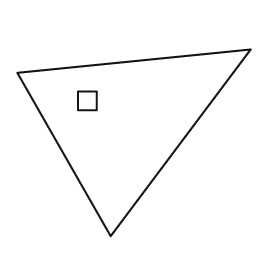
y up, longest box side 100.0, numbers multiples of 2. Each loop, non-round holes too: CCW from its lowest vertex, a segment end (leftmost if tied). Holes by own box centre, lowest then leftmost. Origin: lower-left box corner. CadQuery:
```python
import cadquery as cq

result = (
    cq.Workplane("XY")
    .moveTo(40.0, 0.0)
    .lineTo(100.0, 80.0)
    .lineTo(0.0, 70.0)
    .close()
    .moveTo(26.0, 54.0)
    .lineTo(34.0, 54.0)
    .lineTo(34.0, 62.0)
    .lineTo(26.0, 62.0)
    .close()
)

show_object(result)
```